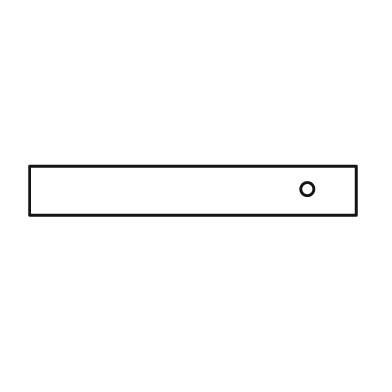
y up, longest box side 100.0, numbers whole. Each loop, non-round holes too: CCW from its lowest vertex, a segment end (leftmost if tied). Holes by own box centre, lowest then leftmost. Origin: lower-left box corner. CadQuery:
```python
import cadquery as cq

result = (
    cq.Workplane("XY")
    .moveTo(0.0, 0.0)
    .lineTo(100.0, 0.0)
    .lineTo(100.0, 15.0)
    .lineTo(0.0, 15.0)
    .close()
    .moveTo(85.0, 8.0)
    .circle(2.0)
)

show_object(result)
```